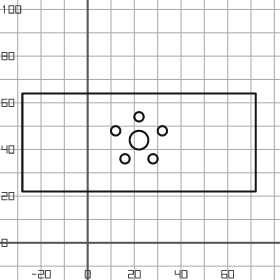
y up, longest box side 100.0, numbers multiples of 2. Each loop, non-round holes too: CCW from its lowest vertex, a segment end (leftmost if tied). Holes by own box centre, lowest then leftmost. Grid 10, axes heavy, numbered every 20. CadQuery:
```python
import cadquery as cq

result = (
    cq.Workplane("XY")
    .moveTo(-28.0, 22.0)
    .lineTo(72.0, 22.0)
    .lineTo(72.0, 64.0)
    .lineTo(-28.0, 64.0)
    .close()
    .moveTo(16.0, 36.0)
    .circle(2.0)
    .moveTo(28.0, 36.0)
    .circle(2.0)
    .moveTo(22.0, 44.0)
    .circle(4.0)
    .moveTo(12.0, 48.0)
    .circle(2.0)
    .moveTo(32.0, 48.0)
    .circle(2.0)
    .moveTo(22.0, 54.0)
    .circle(2.0)
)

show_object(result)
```